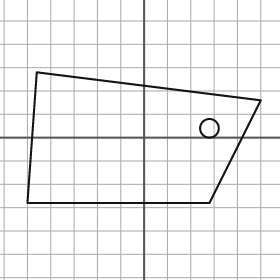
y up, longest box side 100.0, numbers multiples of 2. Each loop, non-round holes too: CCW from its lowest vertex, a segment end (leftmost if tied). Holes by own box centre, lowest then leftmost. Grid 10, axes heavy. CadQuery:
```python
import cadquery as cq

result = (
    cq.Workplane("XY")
    .moveTo(-50.0, -28.0)
    .lineTo(28.0, -28.0)
    .lineTo(50.0, 16.0)
    .lineTo(-46.0, 28.0)
    .close()
    .moveTo(28.0, 4.0)
    .circle(4.0)
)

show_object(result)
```